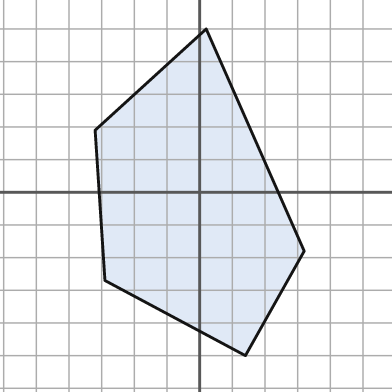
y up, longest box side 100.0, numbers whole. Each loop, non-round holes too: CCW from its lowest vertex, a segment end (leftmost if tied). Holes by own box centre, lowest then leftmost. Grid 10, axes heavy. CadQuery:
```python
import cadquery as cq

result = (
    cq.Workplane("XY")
    .moveTo(14.0, -50.0)
    .lineTo(32.0, -18.0)
    .lineTo(2.0, 50.0)
    .lineTo(-32.0, 19.0)
    .lineTo(-29.0, -27.0)
    .close()
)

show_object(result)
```